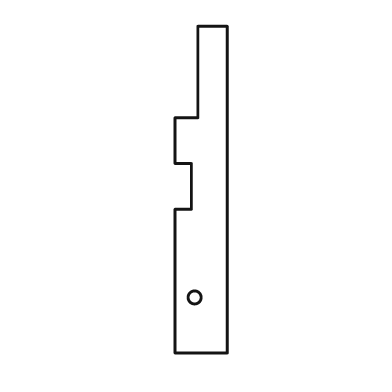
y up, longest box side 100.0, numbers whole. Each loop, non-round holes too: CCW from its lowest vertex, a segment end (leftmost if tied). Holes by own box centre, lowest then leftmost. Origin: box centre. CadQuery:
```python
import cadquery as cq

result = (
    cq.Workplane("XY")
    .moveTo(-8.0, -50.0)
    .lineTo(8.0, -50.0)
    .lineTo(8.0, 50.0)
    .lineTo(-1.0, 50.0)
    .lineTo(-1.0, 22.0)
    .lineTo(-8.0, 22.0)
    .lineTo(-8.0, 8.0)
    .lineTo(-3.0, 8.0)
    .lineTo(-3.0, -6.0)
    .lineTo(-8.0, -6.0)
    .close()
    .moveTo(-2.0, -33.0)
    .circle(2.0)
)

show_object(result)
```